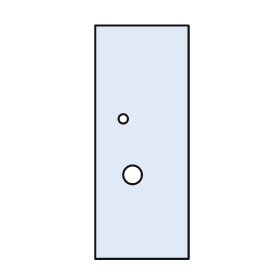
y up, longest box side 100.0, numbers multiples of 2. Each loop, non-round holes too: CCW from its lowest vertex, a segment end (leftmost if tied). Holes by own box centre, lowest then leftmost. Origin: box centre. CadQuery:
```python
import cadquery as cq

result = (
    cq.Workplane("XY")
    .moveTo(-20.0, -50.0)
    .lineTo(20.0, -50.0)
    .lineTo(20.0, 50.0)
    .lineTo(-20.0, 50.0)
    .close()
    .moveTo(-4.0, -14.0)
    .circle(4.0)
    .moveTo(-8.0, 10.0)
    .circle(2.0)
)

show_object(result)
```